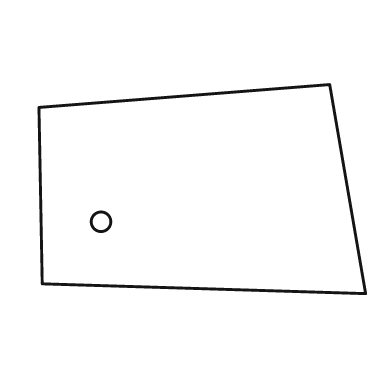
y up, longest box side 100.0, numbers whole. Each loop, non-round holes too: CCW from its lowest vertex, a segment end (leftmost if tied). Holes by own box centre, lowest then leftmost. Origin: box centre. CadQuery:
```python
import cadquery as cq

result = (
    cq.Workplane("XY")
    .moveTo(50.0, -32.0)
    .lineTo(39.0, 32.0)
    .lineTo(-50.0, 25.0)
    .lineTo(-49.0, -29.0)
    .close()
    .moveTo(-31.0, -10.0)
    .circle(3.0)
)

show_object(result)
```